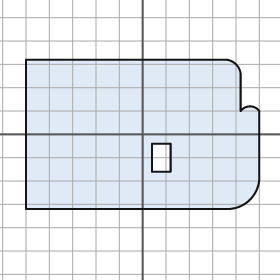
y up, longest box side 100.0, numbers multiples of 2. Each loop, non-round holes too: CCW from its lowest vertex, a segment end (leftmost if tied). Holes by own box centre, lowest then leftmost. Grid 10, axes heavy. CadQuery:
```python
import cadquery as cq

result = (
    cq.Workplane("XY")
    .moveTo(-50.0, -32.0)
    .lineTo(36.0, -32.0)
    .threePointArc((46.0, -28.0), (50.0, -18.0))
    .lineTo(50.0, 10.0)
    .threePointArc((46.0, 12.0), (42.0, 10.0))
    .lineTo(42.0, 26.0)
    .threePointArc((40.0, 30.0), (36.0, 32.0))
    .lineTo(-50.0, 32.0)
    .close()
    .moveTo(4.0, -16.0)
    .lineTo(12.0, -16.0)
    .lineTo(12.0, -4.0)
    .lineTo(4.0, -4.0)
    .close()
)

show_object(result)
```